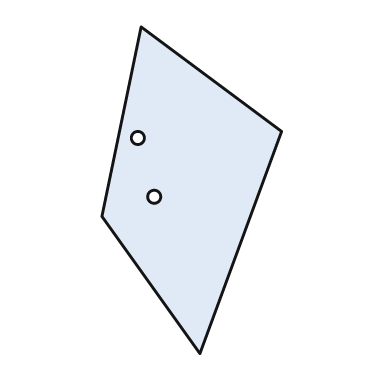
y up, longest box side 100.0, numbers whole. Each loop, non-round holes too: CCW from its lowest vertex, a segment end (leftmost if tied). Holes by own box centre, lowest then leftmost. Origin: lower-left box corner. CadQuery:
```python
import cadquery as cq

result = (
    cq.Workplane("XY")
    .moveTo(30.0, 0.0)
    .lineTo(55.0, 68.0)
    .lineTo(12.0, 100.0)
    .lineTo(0.0, 42.0)
    .close()
    .moveTo(16.0, 48.0)
    .circle(2.0)
    .moveTo(11.0, 66.0)
    .circle(2.0)
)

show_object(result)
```